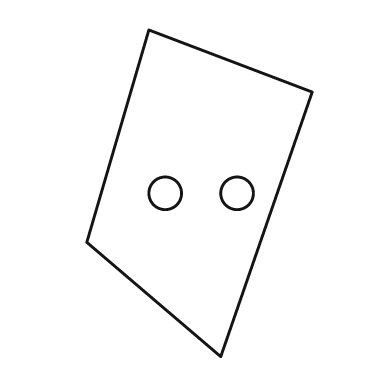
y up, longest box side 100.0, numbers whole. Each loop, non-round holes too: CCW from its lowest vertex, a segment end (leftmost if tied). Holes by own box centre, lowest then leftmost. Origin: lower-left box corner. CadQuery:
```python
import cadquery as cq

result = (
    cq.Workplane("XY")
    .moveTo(41.0, 0.0)
    .lineTo(69.0, 81.0)
    .lineTo(19.0, 100.0)
    .lineTo(0.0, 35.0)
    .close()
    .moveTo(24.0, 50.0)
    .circle(5.0)
    .moveTo(46.0, 50.0)
    .circle(5.0)
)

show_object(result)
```